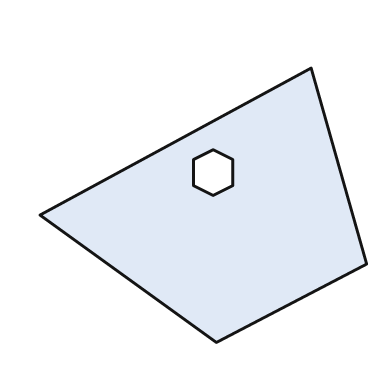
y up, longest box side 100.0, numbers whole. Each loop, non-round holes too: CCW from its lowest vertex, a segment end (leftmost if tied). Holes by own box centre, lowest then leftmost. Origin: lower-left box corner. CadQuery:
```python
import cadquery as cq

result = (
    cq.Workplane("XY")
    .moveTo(54.0, 0.0)
    .lineTo(100.0, 24.0)
    .lineTo(83.0, 84.0)
    .lineTo(0.0, 39.0)
    .close()
    .moveTo(53.0, 45.0)
    .lineTo(59.0, 48.0)
    .lineTo(59.0, 56.0)
    .lineTo(53.0, 59.0)
    .lineTo(47.0, 56.0)
    .lineTo(47.0, 48.0)
    .close()
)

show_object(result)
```